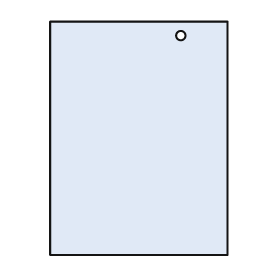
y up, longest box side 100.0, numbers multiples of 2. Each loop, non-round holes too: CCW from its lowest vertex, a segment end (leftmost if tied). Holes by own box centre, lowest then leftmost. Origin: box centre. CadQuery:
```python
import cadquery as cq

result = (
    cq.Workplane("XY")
    .moveTo(-38.0, -50.0)
    .lineTo(38.0, -50.0)
    .lineTo(38.0, 50.0)
    .lineTo(-38.0, 50.0)
    .close()
    .moveTo(18.0, 44.0)
    .circle(2.0)
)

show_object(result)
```